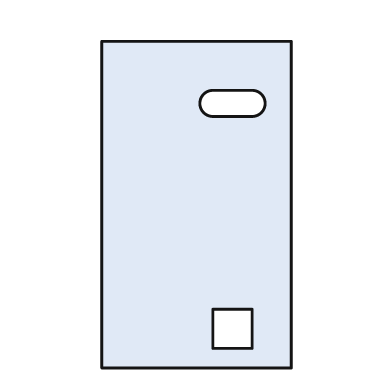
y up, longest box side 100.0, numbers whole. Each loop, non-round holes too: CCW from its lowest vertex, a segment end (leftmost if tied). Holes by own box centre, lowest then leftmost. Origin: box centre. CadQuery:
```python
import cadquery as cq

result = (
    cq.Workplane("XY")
    .moveTo(-29.0, -50.0)
    .lineTo(29.0, -50.0)
    .lineTo(29.0, 50.0)
    .lineTo(-29.0, 50.0)
    .close()
    .moveTo(5.0, -44.0)
    .lineTo(17.0, -44.0)
    .lineTo(17.0, -32.0)
    .lineTo(5.0, -32.0)
    .close()
    .moveTo(5.0, 27.0)
    .lineTo(17.0, 27.0)
    .threePointArc((21.0, 31.0), (17.0, 35.0))
    .lineTo(5.0, 35.0)
    .threePointArc((1.0, 31.0), (5.0, 27.0))
    .close()
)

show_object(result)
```